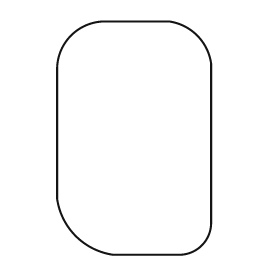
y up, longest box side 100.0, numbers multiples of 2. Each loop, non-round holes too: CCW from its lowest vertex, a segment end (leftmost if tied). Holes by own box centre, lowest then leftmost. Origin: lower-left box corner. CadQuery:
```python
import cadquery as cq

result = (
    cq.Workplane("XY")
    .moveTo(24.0, 0.0)
    .lineTo(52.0, 0.0)
    .threePointArc((62.0, 4.0), (66.0, 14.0))
    .lineTo(66.0, 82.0)
    .threePointArc((60.0, 94.0), (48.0, 100.0))
    .lineTo(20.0, 100.0)
    .threePointArc((6.0, 94.0), (0.0, 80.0))
    .lineTo(0.0, 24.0)
    .threePointArc((8.0, 8.0), (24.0, 0.0))
    .close()
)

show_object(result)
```